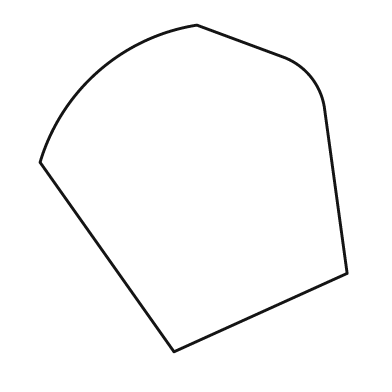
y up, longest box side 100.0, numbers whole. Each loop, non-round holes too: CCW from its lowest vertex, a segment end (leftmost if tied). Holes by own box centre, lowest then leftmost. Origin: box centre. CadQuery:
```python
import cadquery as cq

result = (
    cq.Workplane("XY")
    .moveTo(-6.0, -50.0)
    .lineTo(47.0, -26.0)
    .lineTo(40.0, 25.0)
    .threePointArc((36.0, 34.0), (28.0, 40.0))
    .lineTo(1.0, 50.0)
    .threePointArc((-29.0, 36.0), (-47.0, 8.0))
    .close()
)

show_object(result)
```